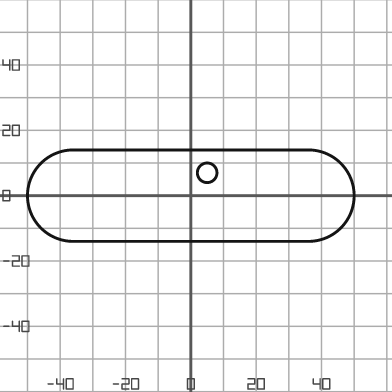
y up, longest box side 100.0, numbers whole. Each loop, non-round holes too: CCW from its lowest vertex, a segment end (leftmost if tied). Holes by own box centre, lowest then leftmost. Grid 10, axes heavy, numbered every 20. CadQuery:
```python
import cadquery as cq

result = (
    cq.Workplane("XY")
    .moveTo(-36.0, -14.0)
    .lineTo(36.0, -14.0)
    .threePointArc((50.0, 0.0), (36.0, 14.0))
    .lineTo(-36.0, 14.0)
    .threePointArc((-50.0, 0.0), (-36.0, -14.0))
    .close()
    .moveTo(5.0, 7.0)
    .circle(3.0)
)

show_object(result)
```